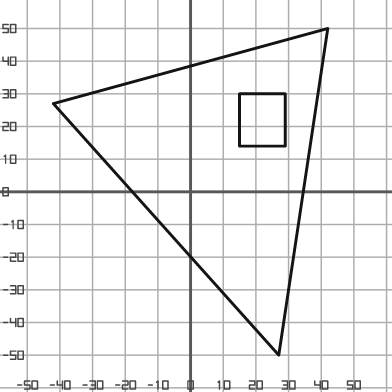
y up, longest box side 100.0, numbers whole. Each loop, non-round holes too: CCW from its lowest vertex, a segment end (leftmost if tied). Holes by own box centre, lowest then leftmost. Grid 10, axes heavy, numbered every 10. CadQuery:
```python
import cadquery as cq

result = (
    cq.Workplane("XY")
    .moveTo(27.0, -50.0)
    .lineTo(42.0, 50.0)
    .lineTo(-42.0, 27.0)
    .close()
    .moveTo(15.0, 14.0)
    .lineTo(29.0, 14.0)
    .lineTo(29.0, 30.0)
    .lineTo(15.0, 30.0)
    .close()
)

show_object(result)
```